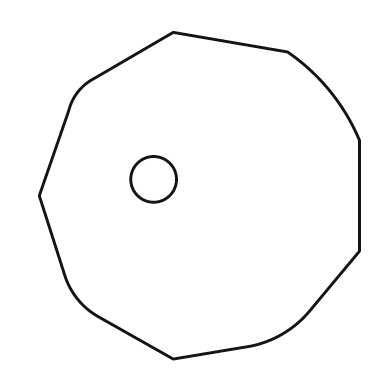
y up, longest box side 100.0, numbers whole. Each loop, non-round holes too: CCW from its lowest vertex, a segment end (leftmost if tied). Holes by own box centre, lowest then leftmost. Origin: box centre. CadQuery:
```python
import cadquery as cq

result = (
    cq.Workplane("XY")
    .moveTo(-8.0, -50.0)
    .lineTo(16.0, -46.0)
    .threePointArc((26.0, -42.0), (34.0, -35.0))
    .lineTo(49.0, -17.0)
    .lineTo(49.0, 17.0)
    .threePointArc((40.0, 32.0), (27.0, 44.0))
    .lineTo(-8.0, 50.0)
    .lineTo(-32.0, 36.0)
    .threePointArc((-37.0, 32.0), (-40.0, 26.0))
    .lineTo(-49.0, 0.0)
    .lineTo(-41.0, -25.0)
    .threePointArc((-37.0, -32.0), (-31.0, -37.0))
    .close()
    .moveTo(-14.0, 5.0)
    .circle(7.0)
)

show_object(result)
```